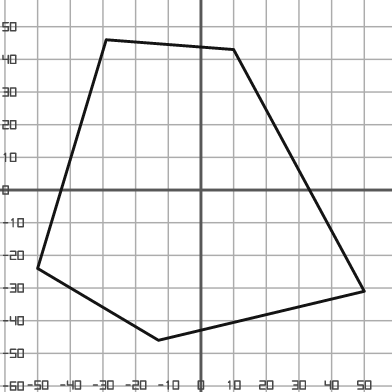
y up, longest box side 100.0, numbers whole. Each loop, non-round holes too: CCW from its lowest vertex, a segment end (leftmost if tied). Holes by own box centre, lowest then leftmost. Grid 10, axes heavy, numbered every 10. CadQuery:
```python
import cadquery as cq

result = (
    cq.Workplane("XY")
    .moveTo(-13.0, -46.0)
    .lineTo(50.0, -31.0)
    .lineTo(10.0, 43.0)
    .lineTo(-29.0, 46.0)
    .lineTo(-50.0, -24.0)
    .close()
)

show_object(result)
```